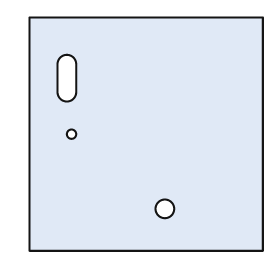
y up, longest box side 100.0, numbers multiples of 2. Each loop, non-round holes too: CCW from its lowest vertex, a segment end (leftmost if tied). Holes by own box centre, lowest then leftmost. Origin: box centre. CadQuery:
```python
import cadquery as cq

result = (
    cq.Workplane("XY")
    .moveTo(-50.0, -50.0)
    .lineTo(50.0, -50.0)
    .lineTo(50.0, 50.0)
    .lineTo(-50.0, 50.0)
    .close()
    .moveTo(8.0, -32.0)
    .circle(4.0)
    .moveTo(-32.0, 0.0)
    .circle(2.0)
    .moveTo(-38.0, 18.0)
    .threePointArc((-34.0, 14.0), (-30.0, 18.0))
    .lineTo(-30.0, 30.0)
    .threePointArc((-34.0, 34.0), (-38.0, 30.0))
    .close()
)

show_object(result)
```